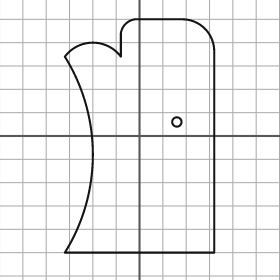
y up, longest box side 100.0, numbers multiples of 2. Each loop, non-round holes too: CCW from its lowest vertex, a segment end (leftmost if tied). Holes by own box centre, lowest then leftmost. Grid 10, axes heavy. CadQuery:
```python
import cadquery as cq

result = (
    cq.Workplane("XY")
    .moveTo(-32.0, -50.0)
    .lineTo(32.0, -50.0)
    .lineTo(32.0, 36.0)
    .threePointArc((28.0, 46.0), (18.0, 50.0))
    .lineTo(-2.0, 50.0)
    .threePointArc((-6.0, 48.0), (-8.0, 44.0))
    .lineTo(-8.0, 34.0)
    .threePointArc((-20.0, 40.0), (-32.0, 34.0))
    .threePointArc((-20.0, -8.0), (-32.0, -50.0))
    .close()
    .moveTo(16.0, 6.0)
    .circle(2.0)
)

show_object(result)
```